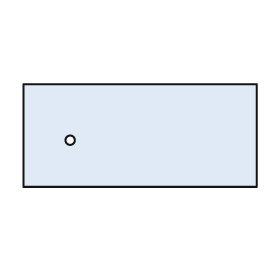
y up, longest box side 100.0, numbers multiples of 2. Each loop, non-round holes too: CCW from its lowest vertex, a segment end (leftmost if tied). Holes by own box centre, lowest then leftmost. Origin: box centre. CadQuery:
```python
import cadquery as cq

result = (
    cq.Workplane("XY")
    .moveTo(-50.0, -22.0)
    .lineTo(50.0, -22.0)
    .lineTo(50.0, 22.0)
    .lineTo(-50.0, 22.0)
    .close()
    .moveTo(-30.0, -2.0)
    .circle(2.0)
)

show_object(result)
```